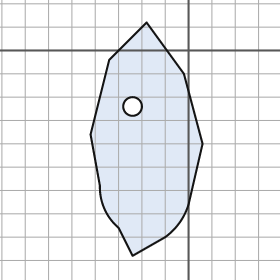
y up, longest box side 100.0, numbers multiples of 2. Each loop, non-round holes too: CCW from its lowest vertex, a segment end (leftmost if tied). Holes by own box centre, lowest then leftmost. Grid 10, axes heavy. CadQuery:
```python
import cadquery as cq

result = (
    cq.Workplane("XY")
    .moveTo(-24.0, -88.0)
    .lineTo(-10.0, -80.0)
    .threePointArc((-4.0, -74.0), (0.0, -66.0))
    .lineTo(6.0, -40.0)
    .lineTo(-2.0, -10.0)
    .lineTo(-18.0, 12.0)
    .lineTo(-34.0, -4.0)
    .lineTo(-42.0, -36.0)
    .lineTo(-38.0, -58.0)
    .threePointArc((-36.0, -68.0), (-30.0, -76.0))
    .close()
    .moveTo(-24.0, -24.0)
    .circle(4.0)
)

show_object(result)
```